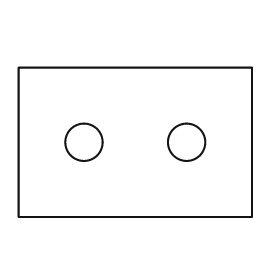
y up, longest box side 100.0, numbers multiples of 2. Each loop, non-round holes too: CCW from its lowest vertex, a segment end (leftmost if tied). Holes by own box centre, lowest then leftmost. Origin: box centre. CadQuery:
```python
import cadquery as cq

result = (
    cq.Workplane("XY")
    .moveTo(-50.0, -32.0)
    .lineTo(50.0, -32.0)
    .lineTo(50.0, 32.0)
    .lineTo(-50.0, 32.0)
    .close()
    .moveTo(-22.0, 0.0)
    .circle(8.0)
    .moveTo(22.0, 0.0)
    .circle(8.0)
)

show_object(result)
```